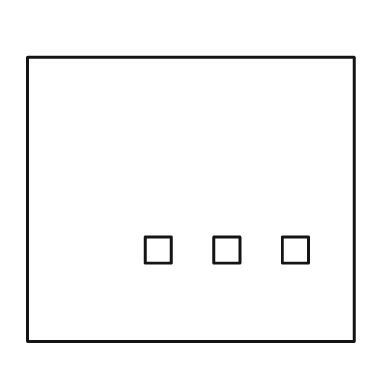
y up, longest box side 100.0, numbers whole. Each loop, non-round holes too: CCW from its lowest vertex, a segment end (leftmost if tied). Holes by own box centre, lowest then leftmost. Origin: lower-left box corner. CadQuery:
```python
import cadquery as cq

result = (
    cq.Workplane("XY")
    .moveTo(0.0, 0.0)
    .lineTo(100.0, 0.0)
    .lineTo(100.0, 87.0)
    .lineTo(0.0, 87.0)
    .close()
    .moveTo(36.0, 24.0)
    .lineTo(44.0, 24.0)
    .lineTo(44.0, 32.0)
    .lineTo(36.0, 32.0)
    .close()
    .moveTo(57.0, 24.0)
    .lineTo(65.0, 24.0)
    .lineTo(65.0, 32.0)
    .lineTo(57.0, 32.0)
    .close()
    .moveTo(78.0, 24.0)
    .lineTo(86.0, 24.0)
    .lineTo(86.0, 32.0)
    .lineTo(78.0, 32.0)
    .close()
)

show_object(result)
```